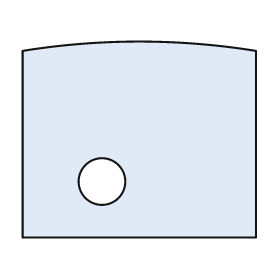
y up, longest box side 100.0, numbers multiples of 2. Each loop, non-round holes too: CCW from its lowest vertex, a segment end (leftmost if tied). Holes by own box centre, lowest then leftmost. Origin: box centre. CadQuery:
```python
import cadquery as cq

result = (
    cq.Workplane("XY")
    .moveTo(-50.0, -42.0)
    .lineTo(50.0, -42.0)
    .lineTo(50.0, 38.0)
    .threePointArc((0.0, 42.0), (-50.0, 38.0))
    .close()
    .moveTo(-16.0, -18.0)
    .circle(10.0)
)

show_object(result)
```